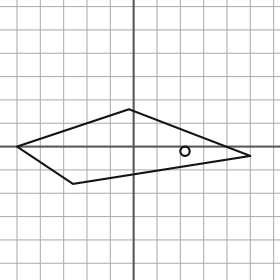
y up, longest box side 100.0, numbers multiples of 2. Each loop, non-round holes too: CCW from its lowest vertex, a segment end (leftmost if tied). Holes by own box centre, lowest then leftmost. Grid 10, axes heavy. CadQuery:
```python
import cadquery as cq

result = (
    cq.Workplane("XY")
    .moveTo(-26.0, -16.0)
    .lineTo(50.0, -4.0)
    .lineTo(-2.0, 16.0)
    .lineTo(-50.0, 0.0)
    .close()
    .moveTo(22.0, -2.0)
    .circle(2.0)
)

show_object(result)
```